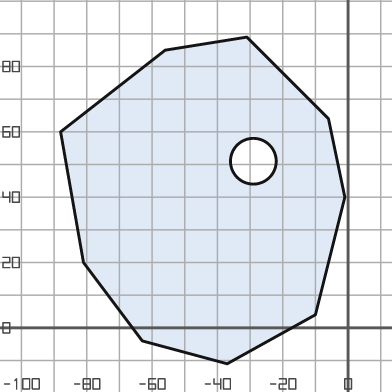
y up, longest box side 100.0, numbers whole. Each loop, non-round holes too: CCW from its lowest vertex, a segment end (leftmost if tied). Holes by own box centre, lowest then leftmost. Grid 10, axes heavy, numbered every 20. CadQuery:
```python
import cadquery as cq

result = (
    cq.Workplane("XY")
    .moveTo(-37.0, -11.0)
    .lineTo(-10.0, 4.0)
    .lineTo(-1.0, 40.0)
    .lineTo(-6.0, 64.0)
    .lineTo(-31.0, 89.0)
    .lineTo(-56.0, 85.0)
    .lineTo(-88.0, 60.0)
    .lineTo(-81.0, 20.0)
    .lineTo(-63.0, -4.0)
    .close()
    .moveTo(-29.0, 51.0)
    .circle(7.0)
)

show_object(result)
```